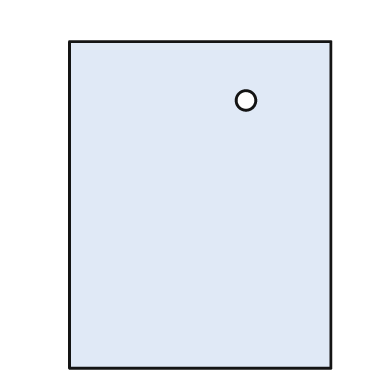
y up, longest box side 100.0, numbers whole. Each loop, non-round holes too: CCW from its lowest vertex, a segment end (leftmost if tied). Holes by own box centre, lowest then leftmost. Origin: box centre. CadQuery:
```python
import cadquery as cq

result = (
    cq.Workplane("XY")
    .moveTo(-40.0, -50.0)
    .lineTo(40.0, -50.0)
    .lineTo(40.0, 50.0)
    .lineTo(-40.0, 50.0)
    .close()
    .moveTo(14.0, 32.0)
    .circle(3.0)
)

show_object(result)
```